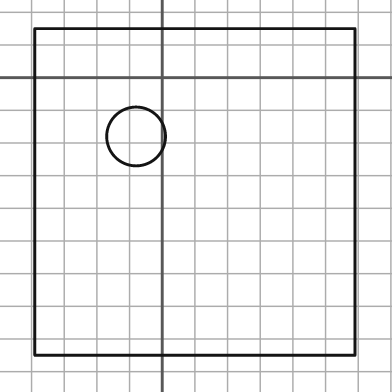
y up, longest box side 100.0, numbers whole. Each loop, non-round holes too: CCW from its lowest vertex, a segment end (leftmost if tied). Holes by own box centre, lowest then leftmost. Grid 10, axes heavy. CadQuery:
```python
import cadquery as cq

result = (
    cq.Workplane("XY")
    .moveTo(-39.0, -85.0)
    .lineTo(59.0, -85.0)
    .lineTo(59.0, 15.0)
    .lineTo(-39.0, 15.0)
    .close()
    .moveTo(-8.0, -18.0)
    .circle(9.0)
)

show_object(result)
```